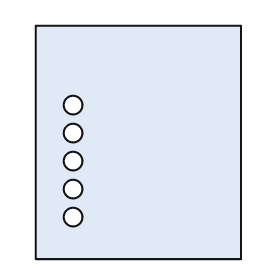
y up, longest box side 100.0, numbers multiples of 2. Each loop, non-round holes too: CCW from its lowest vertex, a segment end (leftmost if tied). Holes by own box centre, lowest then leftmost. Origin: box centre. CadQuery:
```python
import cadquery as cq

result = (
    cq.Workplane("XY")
    .moveTo(-44.0, -50.0)
    .lineTo(44.0, -50.0)
    .lineTo(44.0, 50.0)
    .lineTo(-44.0, 50.0)
    .close()
    .moveTo(-28.0, -32.0)
    .circle(4.0)
    .moveTo(-28.0, -20.0)
    .circle(4.0)
    .moveTo(-28.0, -8.0)
    .circle(4.0)
    .moveTo(-28.0, 4.0)
    .circle(4.0)
    .moveTo(-28.0, 16.0)
    .circle(4.0)
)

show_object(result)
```